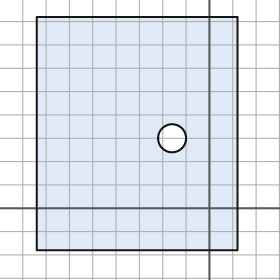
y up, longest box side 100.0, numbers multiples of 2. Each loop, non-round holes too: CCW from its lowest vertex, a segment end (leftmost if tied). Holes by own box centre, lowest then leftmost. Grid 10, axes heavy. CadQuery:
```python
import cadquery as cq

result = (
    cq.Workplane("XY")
    .moveTo(-74.0, -18.0)
    .lineTo(12.0, -18.0)
    .lineTo(12.0, 82.0)
    .lineTo(-74.0, 82.0)
    .close()
    .moveTo(-16.0, 30.0)
    .circle(6.0)
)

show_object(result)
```